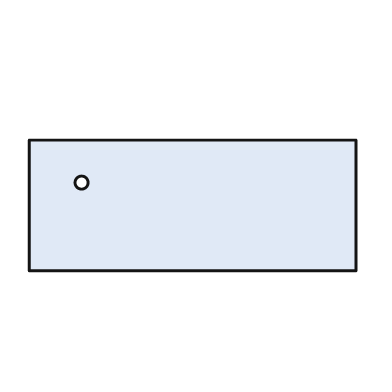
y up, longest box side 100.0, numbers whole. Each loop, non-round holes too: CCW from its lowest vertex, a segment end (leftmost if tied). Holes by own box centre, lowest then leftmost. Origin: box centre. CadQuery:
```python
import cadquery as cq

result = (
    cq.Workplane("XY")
    .moveTo(-50.0, -20.0)
    .lineTo(50.0, -20.0)
    .lineTo(50.0, 20.0)
    .lineTo(-50.0, 20.0)
    .close()
    .moveTo(-34.0, 7.0)
    .circle(2.0)
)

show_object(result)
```